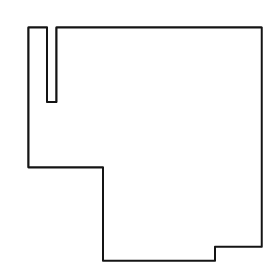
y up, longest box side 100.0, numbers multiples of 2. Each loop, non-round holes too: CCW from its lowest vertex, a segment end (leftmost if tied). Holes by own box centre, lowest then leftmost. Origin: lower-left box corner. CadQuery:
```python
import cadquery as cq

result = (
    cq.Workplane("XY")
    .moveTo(32.0, 0.0)
    .lineTo(80.0, 0.0)
    .lineTo(80.0, 6.0)
    .lineTo(100.0, 6.0)
    .lineTo(100.0, 100.0)
    .lineTo(12.0, 100.0)
    .lineTo(12.0, 68.0)
    .lineTo(8.0, 68.0)
    .lineTo(8.0, 100.0)
    .lineTo(0.0, 100.0)
    .lineTo(0.0, 40.0)
    .lineTo(32.0, 40.0)
    .close()
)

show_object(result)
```